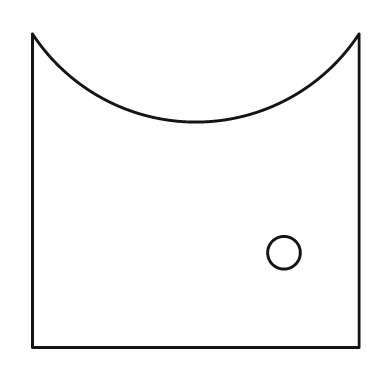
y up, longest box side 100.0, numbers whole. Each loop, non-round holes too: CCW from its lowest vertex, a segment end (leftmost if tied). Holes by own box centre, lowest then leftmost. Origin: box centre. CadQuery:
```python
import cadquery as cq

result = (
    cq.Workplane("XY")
    .moveTo(-50.0, -48.0)
    .lineTo(50.0, -48.0)
    .lineTo(50.0, 48.0)
    .threePointArc((0.0, 21.0), (-50.0, 48.0))
    .close()
    .moveTo(27.0, -19.0)
    .circle(5.0)
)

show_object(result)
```